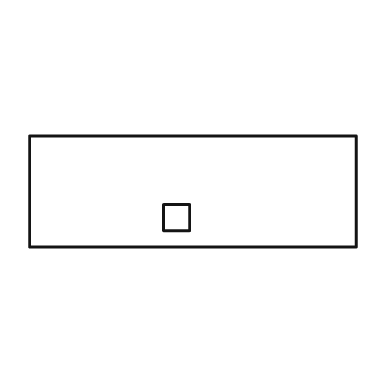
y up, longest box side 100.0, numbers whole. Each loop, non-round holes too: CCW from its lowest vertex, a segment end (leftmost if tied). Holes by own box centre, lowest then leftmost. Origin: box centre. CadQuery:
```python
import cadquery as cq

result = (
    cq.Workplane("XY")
    .moveTo(-50.0, -17.0)
    .lineTo(50.0, -17.0)
    .lineTo(50.0, 17.0)
    .lineTo(-50.0, 17.0)
    .close()
    .moveTo(-9.0, -12.0)
    .lineTo(-1.0, -12.0)
    .lineTo(-1.0, -4.0)
    .lineTo(-9.0, -4.0)
    .close()
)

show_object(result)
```